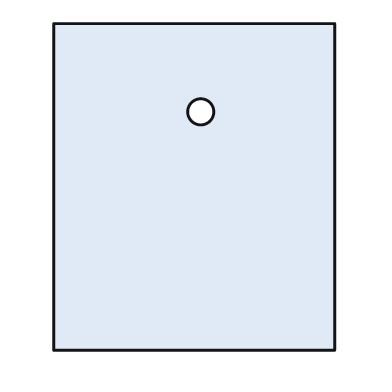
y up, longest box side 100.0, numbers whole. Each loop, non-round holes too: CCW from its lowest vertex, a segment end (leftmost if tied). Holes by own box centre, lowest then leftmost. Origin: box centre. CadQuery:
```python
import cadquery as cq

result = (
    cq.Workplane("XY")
    .moveTo(-43.0, -50.0)
    .lineTo(43.0, -50.0)
    .lineTo(43.0, 50.0)
    .lineTo(-43.0, 50.0)
    .close()
    .moveTo(2.0, 23.0)
    .circle(4.0)
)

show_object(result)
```